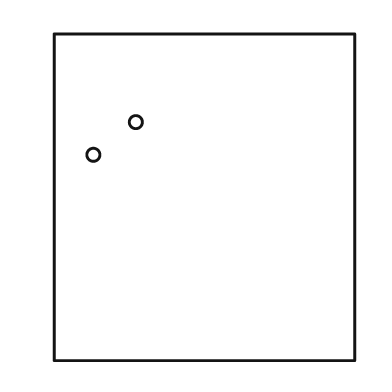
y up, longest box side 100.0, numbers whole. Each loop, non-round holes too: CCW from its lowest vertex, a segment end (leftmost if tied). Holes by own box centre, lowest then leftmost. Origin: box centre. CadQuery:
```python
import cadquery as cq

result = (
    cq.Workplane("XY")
    .moveTo(-46.0, -50.0)
    .lineTo(46.0, -50.0)
    .lineTo(46.0, 50.0)
    .lineTo(-46.0, 50.0)
    .close()
    .moveTo(-34.0, 13.0)
    .circle(2.0)
    .moveTo(-21.0, 23.0)
    .circle(2.0)
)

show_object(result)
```